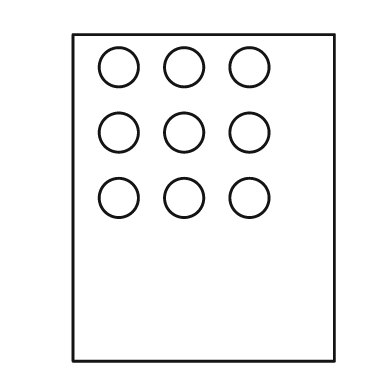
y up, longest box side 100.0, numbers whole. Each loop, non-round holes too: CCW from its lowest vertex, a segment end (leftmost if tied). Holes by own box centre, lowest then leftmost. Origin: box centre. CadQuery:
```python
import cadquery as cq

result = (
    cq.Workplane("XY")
    .moveTo(-40.0, -50.0)
    .lineTo(40.0, -50.0)
    .lineTo(40.0, 50.0)
    .lineTo(-40.0, 50.0)
    .close()
    .moveTo(-26.0, 0.0)
    .circle(6.0)
    .moveTo(-6.0, 0.0)
    .circle(6.0)
    .moveTo(14.0, 0.0)
    .circle(6.0)
    .moveTo(-26.0, 20.0)
    .circle(6.0)
    .moveTo(-6.0, 20.0)
    .circle(6.0)
    .moveTo(14.0, 20.0)
    .circle(6.0)
    .moveTo(-26.0, 40.0)
    .circle(6.0)
    .moveTo(-6.0, 40.0)
    .circle(6.0)
    .moveTo(14.0, 40.0)
    .circle(6.0)
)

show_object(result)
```